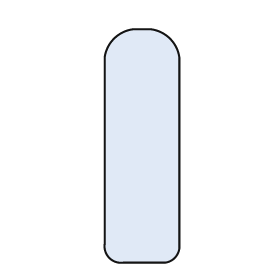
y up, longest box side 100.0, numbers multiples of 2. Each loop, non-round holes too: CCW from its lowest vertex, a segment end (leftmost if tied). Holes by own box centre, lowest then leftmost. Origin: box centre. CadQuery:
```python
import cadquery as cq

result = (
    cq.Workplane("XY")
    .moveTo(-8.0, -50.0)
    .lineTo(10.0, -50.0)
    .threePointArc((14.0, -48.0), (16.0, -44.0))
    .lineTo(16.0, 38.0)
    .threePointArc((12.0, 46.0), (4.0, 50.0))
    .lineTo(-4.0, 50.0)
    .threePointArc((-12.0, 46.0), (-16.0, 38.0))
    .lineTo(-16.0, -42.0)
    .threePointArc((-14.0, -48.0), (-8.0, -50.0))
    .close()
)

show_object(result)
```